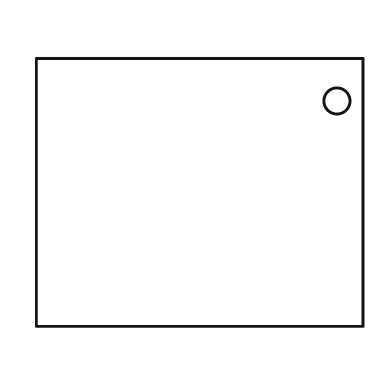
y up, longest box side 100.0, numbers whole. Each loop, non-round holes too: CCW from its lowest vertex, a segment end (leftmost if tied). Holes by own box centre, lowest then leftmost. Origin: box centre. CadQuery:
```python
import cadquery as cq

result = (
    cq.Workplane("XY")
    .moveTo(-50.0, -41.0)
    .lineTo(50.0, -41.0)
    .lineTo(50.0, 41.0)
    .lineTo(-50.0, 41.0)
    .close()
    .moveTo(42.0, 28.0)
    .circle(4.0)
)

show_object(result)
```